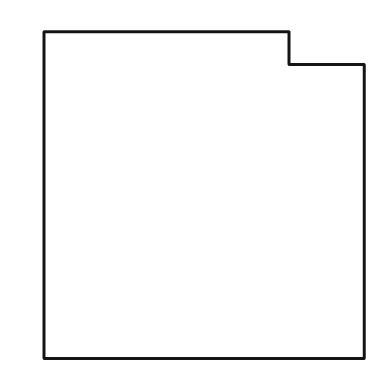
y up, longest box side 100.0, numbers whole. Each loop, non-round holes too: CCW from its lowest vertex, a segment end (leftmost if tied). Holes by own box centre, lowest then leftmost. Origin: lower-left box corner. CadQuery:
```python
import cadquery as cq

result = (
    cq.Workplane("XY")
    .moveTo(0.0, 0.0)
    .lineTo(98.0, 0.0)
    .lineTo(98.0, 90.0)
    .lineTo(75.0, 90.0)
    .lineTo(75.0, 100.0)
    .lineTo(0.0, 100.0)
    .close()
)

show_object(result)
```